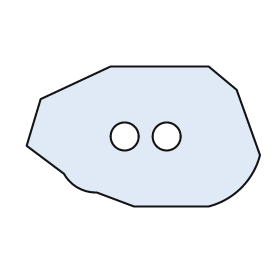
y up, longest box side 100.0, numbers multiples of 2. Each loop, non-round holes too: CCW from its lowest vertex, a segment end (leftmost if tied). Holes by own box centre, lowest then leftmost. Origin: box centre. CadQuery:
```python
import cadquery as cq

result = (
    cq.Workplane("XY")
    .moveTo(-4.0, -30.0)
    .lineTo(28.0, -30.0)
    .threePointArc((42.0, -22.0), (50.0, -8.0))
    .lineTo(40.0, 20.0)
    .lineTo(28.0, 30.0)
    .lineTo(-14.0, 30.0)
    .lineTo(-44.0, 16.0)
    .lineTo(-50.0, -4.0)
    .lineTo(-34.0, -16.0)
    .threePointArc((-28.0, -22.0), (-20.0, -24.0))
    .close()
    .moveTo(-8.0, 0.0)
    .circle(6.0)
    .moveTo(10.0, 0.0)
    .circle(6.0)
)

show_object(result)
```